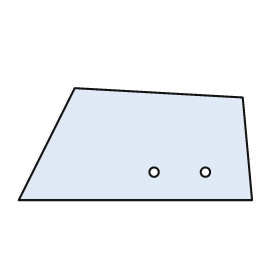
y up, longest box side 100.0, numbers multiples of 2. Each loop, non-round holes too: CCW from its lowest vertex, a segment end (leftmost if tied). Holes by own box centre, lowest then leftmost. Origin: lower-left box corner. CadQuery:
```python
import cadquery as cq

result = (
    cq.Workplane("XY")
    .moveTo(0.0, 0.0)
    .lineTo(100.0, 0.0)
    .lineTo(96.0, 44.0)
    .lineTo(24.0, 48.0)
    .close()
    .moveTo(58.0, 12.0)
    .circle(2.0)
    .moveTo(80.0, 12.0)
    .circle(2.0)
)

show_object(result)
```